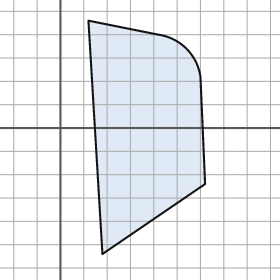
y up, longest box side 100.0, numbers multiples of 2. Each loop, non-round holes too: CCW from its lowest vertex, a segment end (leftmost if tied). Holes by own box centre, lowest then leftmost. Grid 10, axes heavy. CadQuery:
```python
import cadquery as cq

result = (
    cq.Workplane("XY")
    .moveTo(18.0, -54.0)
    .lineTo(62.0, -24.0)
    .lineTo(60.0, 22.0)
    .threePointArc((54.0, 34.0), (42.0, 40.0))
    .lineTo(12.0, 46.0)
    .close()
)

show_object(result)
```